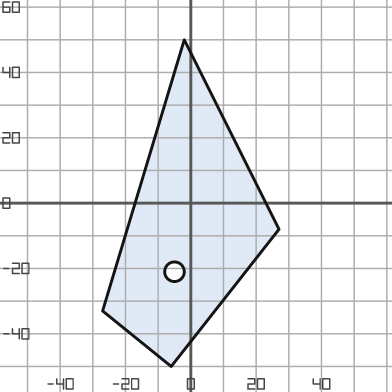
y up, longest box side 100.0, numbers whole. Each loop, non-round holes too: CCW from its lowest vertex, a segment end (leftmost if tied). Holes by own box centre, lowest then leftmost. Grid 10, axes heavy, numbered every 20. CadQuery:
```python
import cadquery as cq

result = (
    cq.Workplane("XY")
    .moveTo(-6.0, -50.0)
    .lineTo(27.0, -8.0)
    .lineTo(-2.0, 50.0)
    .lineTo(-27.0, -33.0)
    .close()
    .moveTo(-5.0, -21.0)
    .circle(3.0)
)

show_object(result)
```